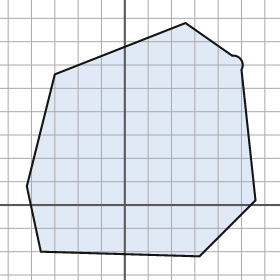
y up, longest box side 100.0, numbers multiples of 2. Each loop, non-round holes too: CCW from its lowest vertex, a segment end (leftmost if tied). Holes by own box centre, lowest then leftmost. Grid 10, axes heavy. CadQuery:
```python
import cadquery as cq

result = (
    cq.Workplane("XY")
    .moveTo(32.0, -22.0)
    .lineTo(56.0, 2.0)
    .lineTo(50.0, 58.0)
    .threePointArc((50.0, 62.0), (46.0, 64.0))
    .lineTo(26.0, 78.0)
    .lineTo(-30.0, 56.0)
    .lineTo(-42.0, 8.0)
    .lineTo(-36.0, -20.0)
    .close()
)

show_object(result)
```